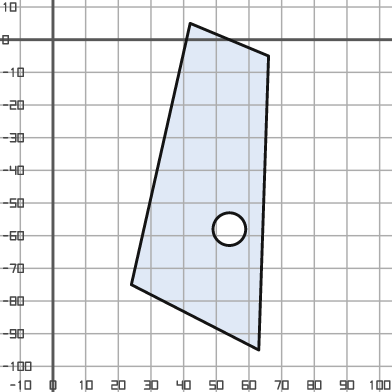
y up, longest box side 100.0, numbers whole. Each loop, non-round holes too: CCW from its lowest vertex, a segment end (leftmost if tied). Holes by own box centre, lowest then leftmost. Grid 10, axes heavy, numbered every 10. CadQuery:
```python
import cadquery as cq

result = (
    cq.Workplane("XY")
    .moveTo(63.0, -95.0)
    .lineTo(66.0, -5.0)
    .lineTo(42.0, 5.0)
    .lineTo(24.0, -75.0)
    .close()
    .moveTo(54.0, -58.0)
    .circle(5.0)
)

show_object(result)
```